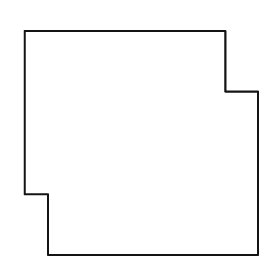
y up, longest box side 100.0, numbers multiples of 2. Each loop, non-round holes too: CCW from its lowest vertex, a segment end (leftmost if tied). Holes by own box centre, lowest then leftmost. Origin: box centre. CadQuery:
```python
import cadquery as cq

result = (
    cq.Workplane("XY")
    .moveTo(-40.0, -48.0)
    .lineTo(50.0, -48.0)
    .lineTo(50.0, 22.0)
    .lineTo(36.0, 22.0)
    .lineTo(36.0, 48.0)
    .lineTo(-50.0, 48.0)
    .lineTo(-50.0, -22.0)
    .lineTo(-40.0, -22.0)
    .close()
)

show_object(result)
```